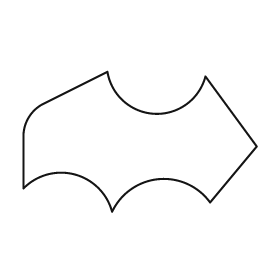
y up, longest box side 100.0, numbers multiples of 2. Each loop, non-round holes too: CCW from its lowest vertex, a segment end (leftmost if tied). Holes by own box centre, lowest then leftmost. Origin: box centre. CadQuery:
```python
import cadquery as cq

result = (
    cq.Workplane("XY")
    .moveTo(-12.0, -30.0)
    .threePointArc((8.0, -16.0), (30.0, -26.0))
    .lineTo(50.0, -2.0)
    .lineTo(28.0, 28.0)
    .threePointArc((6.0, 12.0), (-14.0, 30.0))
    .lineTo(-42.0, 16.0)
    .threePointArc((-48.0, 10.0), (-50.0, 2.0))
    .lineTo(-50.0, -20.0)
    .threePointArc((-28.0, -14.0), (-12.0, -30.0))
    .close()
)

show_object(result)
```